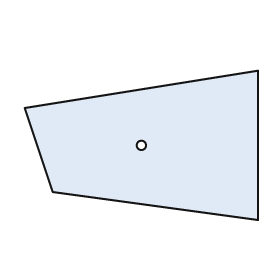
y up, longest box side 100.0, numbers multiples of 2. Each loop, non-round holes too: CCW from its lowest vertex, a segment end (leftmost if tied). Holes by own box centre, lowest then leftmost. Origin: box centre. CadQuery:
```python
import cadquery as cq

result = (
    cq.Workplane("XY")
    .moveTo(50.0, -32.0)
    .lineTo(50.0, 32.0)
    .lineTo(-50.0, 16.0)
    .lineTo(-38.0, -20.0)
    .close()
    .moveTo(0.0, 0.0)
    .circle(2.0)
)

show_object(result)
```